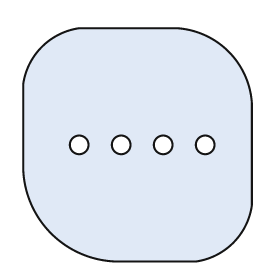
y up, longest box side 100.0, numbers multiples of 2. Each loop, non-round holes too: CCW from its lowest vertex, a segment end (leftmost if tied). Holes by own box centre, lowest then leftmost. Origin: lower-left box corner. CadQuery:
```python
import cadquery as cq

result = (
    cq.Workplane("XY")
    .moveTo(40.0, 0.0)
    .lineTo(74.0, 0.0)
    .threePointArc((90.0, 8.0), (98.0, 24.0))
    .lineTo(98.0, 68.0)
    .threePointArc((88.0, 90.0), (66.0, 100.0))
    .lineTo(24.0, 100.0)
    .threePointArc((8.0, 92.0), (0.0, 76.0))
    .lineTo(0.0, 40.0)
    .threePointArc((12.0, 12.0), (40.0, 0.0))
    .close()
    .moveTo(24.0, 50.0)
    .circle(4.0)
    .moveTo(42.0, 50.0)
    .circle(4.0)
    .moveTo(60.0, 50.0)
    .circle(4.0)
    .moveTo(78.0, 50.0)
    .circle(4.0)
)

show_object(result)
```